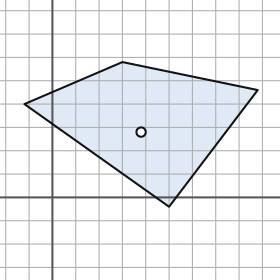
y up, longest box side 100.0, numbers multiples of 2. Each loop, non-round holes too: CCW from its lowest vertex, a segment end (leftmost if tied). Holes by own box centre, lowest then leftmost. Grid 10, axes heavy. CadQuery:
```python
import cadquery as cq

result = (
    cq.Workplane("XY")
    .moveTo(50.0, -4.0)
    .lineTo(88.0, 46.0)
    .lineTo(30.0, 58.0)
    .lineTo(-12.0, 40.0)
    .close()
    .moveTo(38.0, 28.0)
    .circle(2.0)
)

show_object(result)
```